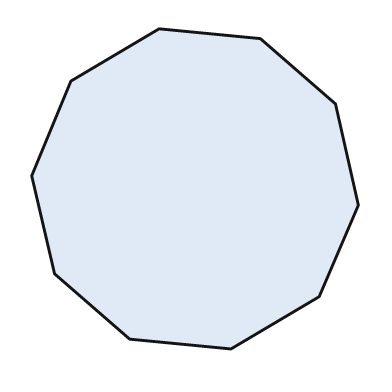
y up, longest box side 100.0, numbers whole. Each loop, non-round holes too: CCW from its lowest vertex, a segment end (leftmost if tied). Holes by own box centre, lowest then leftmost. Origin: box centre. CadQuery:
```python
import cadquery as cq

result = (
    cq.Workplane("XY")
    .moveTo(11.0, -49.0)
    .lineTo(38.0, -33.0)
    .lineTo(50.0, -5.0)
    .lineTo(43.0, 26.0)
    .lineTo(20.0, 46.0)
    .lineTo(-11.0, 49.0)
    .lineTo(-38.0, 33.0)
    .lineTo(-50.0, 4.0)
    .lineTo(-43.0, -26.0)
    .lineTo(-20.0, -46.0)
    .close()
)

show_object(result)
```